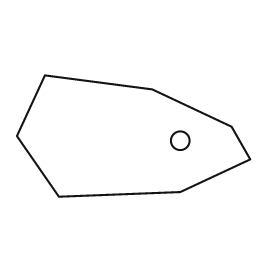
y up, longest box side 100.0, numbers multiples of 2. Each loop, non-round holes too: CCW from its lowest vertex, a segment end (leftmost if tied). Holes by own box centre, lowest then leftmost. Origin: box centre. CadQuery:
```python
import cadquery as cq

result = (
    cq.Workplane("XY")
    .moveTo(-32.0, -26.0)
    .lineTo(20.0, -24.0)
    .lineTo(50.0, -10.0)
    .lineTo(42.0, 4.0)
    .lineTo(8.0, 20.0)
    .lineTo(-38.0, 26.0)
    .lineTo(-50.0, 0.0)
    .close()
    .moveTo(20.0, -2.0)
    .circle(4.0)
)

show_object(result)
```